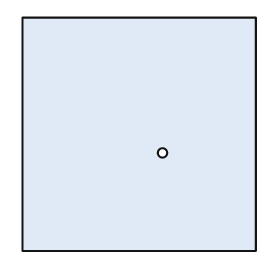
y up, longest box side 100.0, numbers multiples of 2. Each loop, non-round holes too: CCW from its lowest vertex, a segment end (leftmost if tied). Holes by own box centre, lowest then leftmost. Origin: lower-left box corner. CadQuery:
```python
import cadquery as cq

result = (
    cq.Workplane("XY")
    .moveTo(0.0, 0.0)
    .lineTo(100.0, 0.0)
    .lineTo(100.0, 100.0)
    .lineTo(0.0, 100.0)
    .close()
    .moveTo(60.0, 42.0)
    .circle(2.0)
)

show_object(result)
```